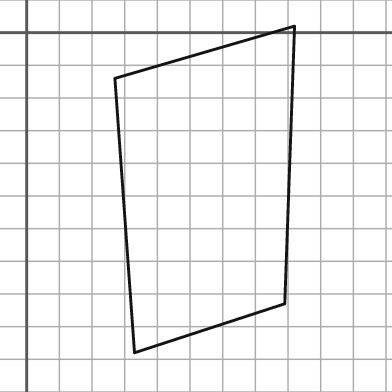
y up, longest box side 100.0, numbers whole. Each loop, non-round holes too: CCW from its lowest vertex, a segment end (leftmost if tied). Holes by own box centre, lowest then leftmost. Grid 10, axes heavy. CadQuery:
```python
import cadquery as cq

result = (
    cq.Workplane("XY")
    .moveTo(33.0, -98.0)
    .lineTo(79.0, -83.0)
    .lineTo(82.0, 2.0)
    .lineTo(27.0, -14.0)
    .close()
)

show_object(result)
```